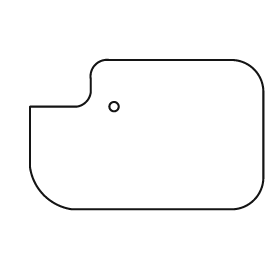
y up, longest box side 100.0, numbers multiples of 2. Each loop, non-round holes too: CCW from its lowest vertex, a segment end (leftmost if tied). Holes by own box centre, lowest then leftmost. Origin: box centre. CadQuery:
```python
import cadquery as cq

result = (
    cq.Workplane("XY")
    .moveTo(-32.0, -32.0)
    .lineTo(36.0, -32.0)
    .threePointArc((46.0, -28.0), (50.0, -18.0))
    .lineTo(50.0, 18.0)
    .threePointArc((46.0, 28.0), (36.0, 32.0))
    .lineTo(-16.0, 32.0)
    .threePointArc((-22.0, 30.0), (-24.0, 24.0))
    .lineTo(-24.0, 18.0)
    .threePointArc((-26.0, 14.0), (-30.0, 12.0))
    .lineTo(-50.0, 12.0)
    .lineTo(-50.0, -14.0)
    .threePointArc((-44.0, -26.0), (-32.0, -32.0))
    .close()
    .moveTo(-14.0, 12.0)
    .circle(2.0)
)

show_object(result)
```